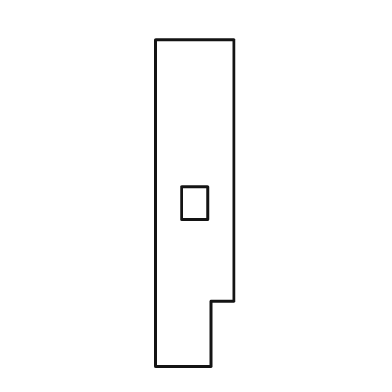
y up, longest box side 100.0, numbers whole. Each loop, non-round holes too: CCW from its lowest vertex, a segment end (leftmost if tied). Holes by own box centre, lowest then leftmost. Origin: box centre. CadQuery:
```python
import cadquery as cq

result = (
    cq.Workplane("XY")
    .moveTo(-12.0, -50.0)
    .lineTo(5.0, -50.0)
    .lineTo(5.0, -30.0)
    .lineTo(12.0, -30.0)
    .lineTo(12.0, 50.0)
    .lineTo(-12.0, 50.0)
    .close()
    .moveTo(-4.0, -5.0)
    .lineTo(4.0, -5.0)
    .lineTo(4.0, 5.0)
    .lineTo(-4.0, 5.0)
    .close()
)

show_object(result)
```